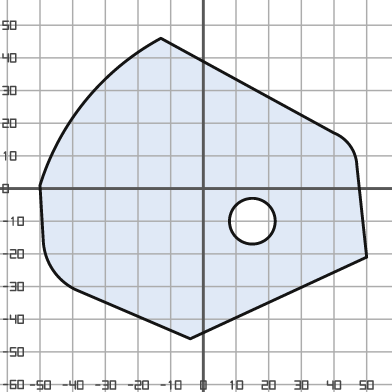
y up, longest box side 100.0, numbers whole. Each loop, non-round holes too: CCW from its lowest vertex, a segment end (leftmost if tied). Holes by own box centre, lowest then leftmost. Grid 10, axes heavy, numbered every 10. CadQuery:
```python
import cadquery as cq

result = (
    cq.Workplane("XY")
    .moveTo(-4.0, -46.0)
    .lineTo(50.0, -21.0)
    .lineTo(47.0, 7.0)
    .threePointArc((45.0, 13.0), (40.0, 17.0))
    .lineTo(-13.0, 46.0)
    .threePointArc((-36.0, 27.0), (-50.0, 1.0))
    .lineTo(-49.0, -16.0)
    .threePointArc((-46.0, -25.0), (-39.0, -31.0))
    .close()
    .moveTo(15.0, -10.0)
    .circle(7.0)
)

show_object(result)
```